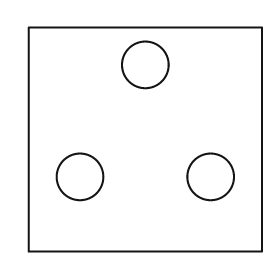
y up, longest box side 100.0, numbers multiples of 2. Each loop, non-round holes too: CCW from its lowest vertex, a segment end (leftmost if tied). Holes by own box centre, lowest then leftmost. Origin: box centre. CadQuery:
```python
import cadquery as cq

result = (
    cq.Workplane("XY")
    .moveTo(-50.0, -48.0)
    .lineTo(50.0, -48.0)
    .lineTo(50.0, 48.0)
    .lineTo(-50.0, 48.0)
    .close()
    .moveTo(-28.0, -16.0)
    .circle(10.0)
    .moveTo(28.0, -16.0)
    .circle(10.0)
    .moveTo(0.0, 32.0)
    .circle(10.0)
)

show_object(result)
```